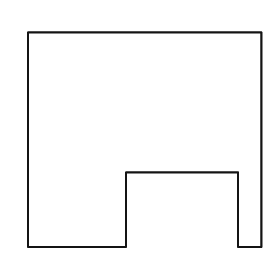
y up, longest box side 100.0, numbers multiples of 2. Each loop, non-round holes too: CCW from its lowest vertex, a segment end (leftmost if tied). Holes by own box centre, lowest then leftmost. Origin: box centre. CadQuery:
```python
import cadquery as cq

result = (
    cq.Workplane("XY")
    .moveTo(-50.0, -46.0)
    .lineTo(-8.0, -46.0)
    .lineTo(-8.0, -14.0)
    .lineTo(40.0, -14.0)
    .lineTo(40.0, -46.0)
    .lineTo(50.0, -46.0)
    .lineTo(50.0, 46.0)
    .lineTo(-50.0, 46.0)
    .close()
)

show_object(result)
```